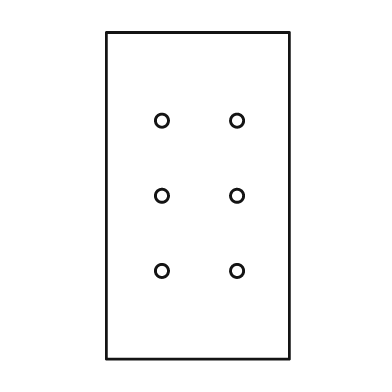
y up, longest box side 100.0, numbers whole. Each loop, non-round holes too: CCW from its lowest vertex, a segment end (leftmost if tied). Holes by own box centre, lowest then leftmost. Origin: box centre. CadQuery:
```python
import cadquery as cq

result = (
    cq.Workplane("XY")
    .moveTo(-28.0, -50.0)
    .lineTo(28.0, -50.0)
    .lineTo(28.0, 50.0)
    .lineTo(-28.0, 50.0)
    .close()
    .moveTo(-11.0, -23.0)
    .circle(2.0)
    .moveTo(12.0, -23.0)
    .circle(2.0)
    .moveTo(-11.0, 0.0)
    .circle(2.0)
    .moveTo(12.0, 0.0)
    .circle(2.0)
    .moveTo(-11.0, 23.0)
    .circle(2.0)
    .moveTo(12.0, 23.0)
    .circle(2.0)
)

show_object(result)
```